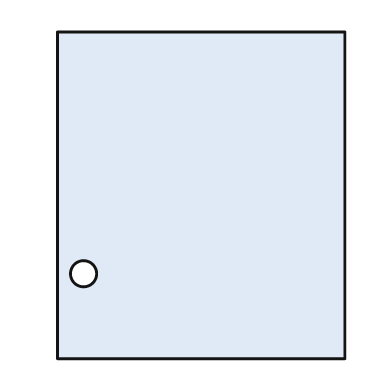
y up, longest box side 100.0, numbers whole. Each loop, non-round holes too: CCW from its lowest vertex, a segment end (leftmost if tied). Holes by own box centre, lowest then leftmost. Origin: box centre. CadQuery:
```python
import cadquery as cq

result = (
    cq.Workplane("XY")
    .moveTo(-44.0, -50.0)
    .lineTo(44.0, -50.0)
    .lineTo(44.0, 50.0)
    .lineTo(-44.0, 50.0)
    .close()
    .moveTo(-36.0, -24.0)
    .circle(4.0)
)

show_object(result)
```